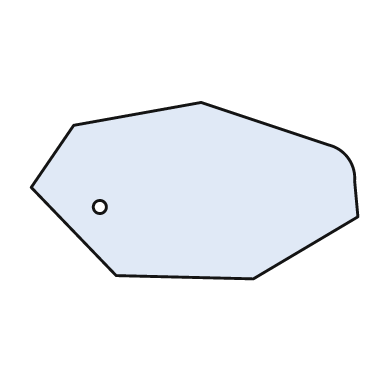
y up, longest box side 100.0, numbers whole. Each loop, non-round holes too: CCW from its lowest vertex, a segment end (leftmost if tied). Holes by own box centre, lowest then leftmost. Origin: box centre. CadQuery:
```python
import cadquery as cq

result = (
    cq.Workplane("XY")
    .moveTo(18.0, -27.0)
    .lineTo(50.0, -8.0)
    .lineTo(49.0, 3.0)
    .threePointArc((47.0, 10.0), (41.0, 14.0))
    .lineTo(2.0, 27.0)
    .lineTo(-37.0, 20.0)
    .lineTo(-50.0, 1.0)
    .lineTo(-24.0, -26.0)
    .close()
    .moveTo(-29.0, -5.0)
    .circle(2.0)
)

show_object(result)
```